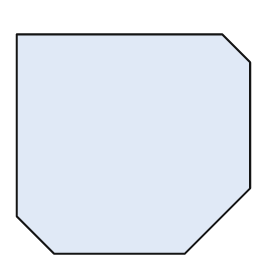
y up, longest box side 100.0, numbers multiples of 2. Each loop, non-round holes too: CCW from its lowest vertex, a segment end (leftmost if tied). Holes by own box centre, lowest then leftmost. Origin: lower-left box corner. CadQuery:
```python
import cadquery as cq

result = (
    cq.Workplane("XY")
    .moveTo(16.0, 0.0)
    .lineTo(72.0, 0.0)
    .lineTo(100.0, 28.0)
    .lineTo(100.0, 82.0)
    .lineTo(88.0, 94.0)
    .lineTo(0.0, 94.0)
    .lineTo(0.0, 16.0)
    .close()
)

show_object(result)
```